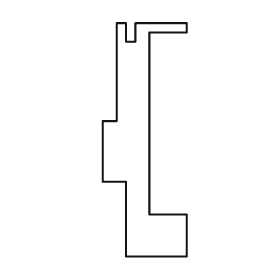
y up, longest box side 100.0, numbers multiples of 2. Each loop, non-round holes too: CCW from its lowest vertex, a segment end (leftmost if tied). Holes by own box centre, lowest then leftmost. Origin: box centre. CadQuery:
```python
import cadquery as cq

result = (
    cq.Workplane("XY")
    .moveTo(-8.0, -50.0)
    .lineTo(18.0, -50.0)
    .lineTo(18.0, -32.0)
    .lineTo(2.0, -32.0)
    .lineTo(2.0, 46.0)
    .lineTo(18.0, 46.0)
    .lineTo(18.0, 50.0)
    .lineTo(-4.0, 50.0)
    .lineTo(-4.0, 42.0)
    .lineTo(-8.0, 42.0)
    .lineTo(-8.0, 50.0)
    .lineTo(-12.0, 50.0)
    .lineTo(-12.0, 8.0)
    .lineTo(-18.0, 8.0)
    .lineTo(-18.0, -18.0)
    .lineTo(-8.0, -18.0)
    .close()
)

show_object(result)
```